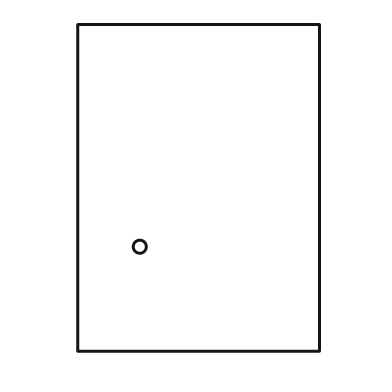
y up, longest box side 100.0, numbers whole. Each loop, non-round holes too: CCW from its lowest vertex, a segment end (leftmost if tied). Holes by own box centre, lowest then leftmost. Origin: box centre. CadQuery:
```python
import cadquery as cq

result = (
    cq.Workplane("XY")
    .moveTo(-37.0, -50.0)
    .lineTo(37.0, -50.0)
    .lineTo(37.0, 50.0)
    .lineTo(-37.0, 50.0)
    .close()
    .moveTo(-18.0, -18.0)
    .circle(2.0)
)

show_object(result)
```